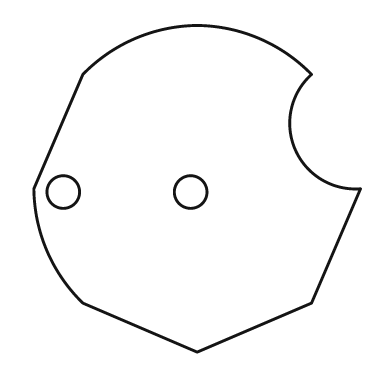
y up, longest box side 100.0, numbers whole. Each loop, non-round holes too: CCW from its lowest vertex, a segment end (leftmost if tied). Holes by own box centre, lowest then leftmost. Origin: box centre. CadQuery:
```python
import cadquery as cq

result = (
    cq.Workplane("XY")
    .moveTo(0.0, -50.0)
    .lineTo(35.0, -35.0)
    .lineTo(50.0, 0.0)
    .threePointArc((30.0, 12.0), (35.0, 35.0))
    .threePointArc((19.0, 46.0), (0.0, 50.0))
    .threePointArc((-19.0, 46.0), (-35.0, 35.0))
    .lineTo(-50.0, 0.0)
    .threePointArc((-46.0, -19.0), (-35.0, -35.0))
    .close()
    .moveTo(-41.0, -1.0)
    .circle(5.0)
    .moveTo(-2.0, -1.0)
    .circle(5.0)
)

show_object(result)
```